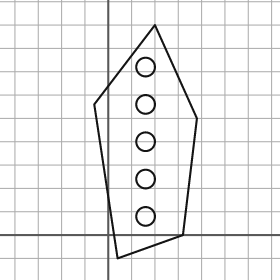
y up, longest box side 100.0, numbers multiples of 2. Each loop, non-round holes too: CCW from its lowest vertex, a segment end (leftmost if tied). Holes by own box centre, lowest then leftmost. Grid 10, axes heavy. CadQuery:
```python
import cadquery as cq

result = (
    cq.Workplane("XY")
    .moveTo(4.0, -10.0)
    .lineTo(32.0, 0.0)
    .lineTo(38.0, 50.0)
    .lineTo(20.0, 90.0)
    .lineTo(-6.0, 56.0)
    .close()
    .moveTo(16.0, 8.0)
    .circle(4.0)
    .moveTo(16.0, 24.0)
    .circle(4.0)
    .moveTo(16.0, 40.0)
    .circle(4.0)
    .moveTo(16.0, 56.0)
    .circle(4.0)
    .moveTo(16.0, 72.0)
    .circle(4.0)
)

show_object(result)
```